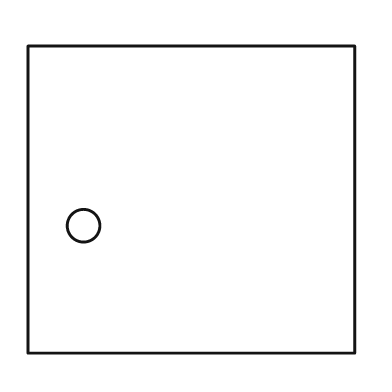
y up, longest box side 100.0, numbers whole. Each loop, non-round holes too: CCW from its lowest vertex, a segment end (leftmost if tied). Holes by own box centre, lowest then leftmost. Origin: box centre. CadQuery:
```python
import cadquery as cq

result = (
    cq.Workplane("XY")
    .moveTo(-50.0, -47.0)
    .lineTo(50.0, -47.0)
    .lineTo(50.0, 47.0)
    .lineTo(-50.0, 47.0)
    .close()
    .moveTo(-33.0, -8.0)
    .circle(5.0)
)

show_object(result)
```